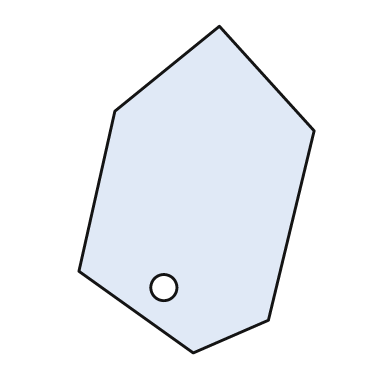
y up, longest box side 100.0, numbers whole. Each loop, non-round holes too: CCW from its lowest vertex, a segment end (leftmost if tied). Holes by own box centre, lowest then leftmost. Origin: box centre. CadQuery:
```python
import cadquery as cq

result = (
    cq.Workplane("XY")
    .moveTo(-1.0, -50.0)
    .lineTo(22.0, -40.0)
    .lineTo(36.0, 18.0)
    .lineTo(7.0, 50.0)
    .lineTo(-25.0, 24.0)
    .lineTo(-36.0, -25.0)
    .close()
    .moveTo(-10.0, -30.0)
    .circle(4.0)
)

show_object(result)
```